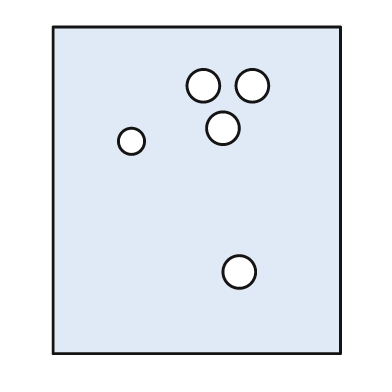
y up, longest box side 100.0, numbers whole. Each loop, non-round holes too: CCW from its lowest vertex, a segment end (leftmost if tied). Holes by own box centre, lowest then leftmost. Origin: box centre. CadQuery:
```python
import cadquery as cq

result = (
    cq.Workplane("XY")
    .moveTo(-44.0, -50.0)
    .lineTo(44.0, -50.0)
    .lineTo(44.0, 50.0)
    .lineTo(-44.0, 50.0)
    .close()
    .moveTo(13.0, -25.0)
    .circle(5.0)
    .moveTo(-20.0, 15.0)
    .circle(4.0)
    .moveTo(8.0, 19.0)
    .circle(5.0)
    .moveTo(2.0, 32.0)
    .circle(5.0)
    .moveTo(17.0, 32.0)
    .circle(5.0)
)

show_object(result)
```